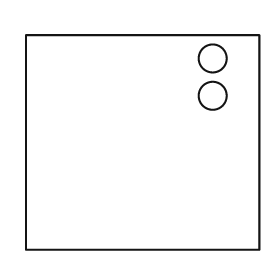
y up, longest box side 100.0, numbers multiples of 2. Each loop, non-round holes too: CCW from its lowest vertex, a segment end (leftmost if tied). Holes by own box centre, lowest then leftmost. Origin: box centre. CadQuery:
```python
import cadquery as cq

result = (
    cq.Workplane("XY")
    .moveTo(-50.0, -46.0)
    .lineTo(50.0, -46.0)
    .lineTo(50.0, 46.0)
    .lineTo(-50.0, 46.0)
    .close()
    .moveTo(30.0, 20.0)
    .circle(6.0)
    .moveTo(30.0, 36.0)
    .circle(6.0)
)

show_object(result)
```